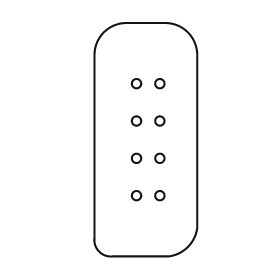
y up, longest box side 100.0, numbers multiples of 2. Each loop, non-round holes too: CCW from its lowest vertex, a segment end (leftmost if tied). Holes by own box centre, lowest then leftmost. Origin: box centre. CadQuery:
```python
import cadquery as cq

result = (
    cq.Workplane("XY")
    .moveTo(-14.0, -50.0)
    .lineTo(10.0, -50.0)
    .threePointArc((18.0, -46.0), (22.0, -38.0))
    .lineTo(22.0, 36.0)
    .threePointArc((18.0, 46.0), (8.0, 50.0))
    .lineTo(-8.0, 50.0)
    .threePointArc((-18.0, 46.0), (-22.0, 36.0))
    .lineTo(-22.0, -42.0)
    .threePointArc((-20.0, -48.0), (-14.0, -50.0))
    .close()
    .moveTo(-4.0, -24.0)
    .circle(2.0)
    .moveTo(6.0, -24.0)
    .circle(2.0)
    .moveTo(-4.0, -8.0)
    .circle(2.0)
    .moveTo(6.0, -8.0)
    .circle(2.0)
    .moveTo(-4.0, 8.0)
    .circle(2.0)
    .moveTo(6.0, 8.0)
    .circle(2.0)
    .moveTo(-4.0, 24.0)
    .circle(2.0)
    .moveTo(6.0, 24.0)
    .circle(2.0)
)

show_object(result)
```